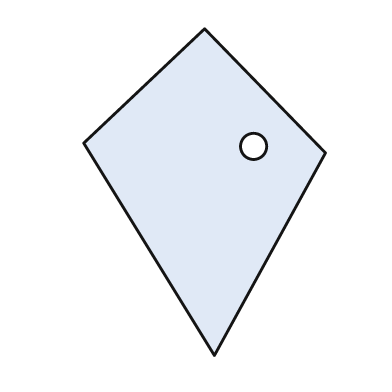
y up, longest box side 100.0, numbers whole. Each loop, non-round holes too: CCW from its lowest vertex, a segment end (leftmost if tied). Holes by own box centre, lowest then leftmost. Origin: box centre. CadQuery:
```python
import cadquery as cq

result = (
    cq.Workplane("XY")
    .moveTo(3.0, -50.0)
    .lineTo(37.0, 12.0)
    .lineTo(0.0, 50.0)
    .lineTo(-37.0, 15.0)
    .close()
    .moveTo(15.0, 14.0)
    .circle(4.0)
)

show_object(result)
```